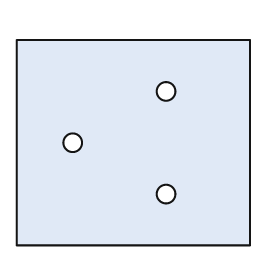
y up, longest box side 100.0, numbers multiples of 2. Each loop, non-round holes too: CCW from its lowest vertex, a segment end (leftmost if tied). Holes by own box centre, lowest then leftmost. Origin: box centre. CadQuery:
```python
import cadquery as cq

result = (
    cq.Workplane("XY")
    .moveTo(-50.0, -44.0)
    .lineTo(50.0, -44.0)
    .lineTo(50.0, 44.0)
    .lineTo(-50.0, 44.0)
    .close()
    .moveTo(14.0, -22.0)
    .circle(4.0)
    .moveTo(-26.0, 0.0)
    .circle(4.0)
    .moveTo(14.0, 22.0)
    .circle(4.0)
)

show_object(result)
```